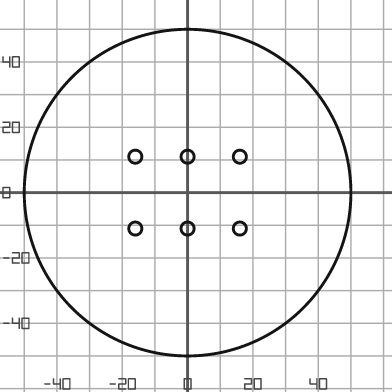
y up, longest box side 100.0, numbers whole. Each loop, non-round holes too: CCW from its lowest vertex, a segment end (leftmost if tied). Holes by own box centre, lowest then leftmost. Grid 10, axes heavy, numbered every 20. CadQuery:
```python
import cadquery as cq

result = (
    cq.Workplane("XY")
    .moveTo(0.0, 0.0)
    .circle(50.0)
    .moveTo(-16.0, -11.0)
    .circle(2.0)
    .moveTo(0.0, -11.0)
    .circle(2.0)
    .moveTo(16.0, -11.0)
    .circle(2.0)
    .moveTo(-16.0, 11.0)
    .circle(2.0)
    .moveTo(0.0, 11.0)
    .circle(2.0)
    .moveTo(16.0, 11.0)
    .circle(2.0)
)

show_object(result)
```